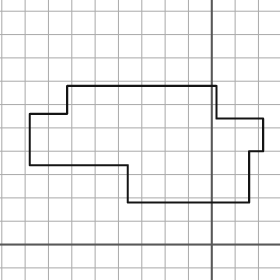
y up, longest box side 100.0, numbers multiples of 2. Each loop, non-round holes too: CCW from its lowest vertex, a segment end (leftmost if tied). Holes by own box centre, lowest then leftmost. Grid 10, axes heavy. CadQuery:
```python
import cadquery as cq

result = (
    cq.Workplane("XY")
    .moveTo(-36.0, 18.0)
    .lineTo(16.0, 18.0)
    .lineTo(16.0, 40.0)
    .lineTo(22.0, 40.0)
    .lineTo(22.0, 54.0)
    .lineTo(2.0, 54.0)
    .lineTo(2.0, 68.0)
    .lineTo(-62.0, 68.0)
    .lineTo(-62.0, 56.0)
    .lineTo(-78.0, 56.0)
    .lineTo(-78.0, 34.0)
    .lineTo(-36.0, 34.0)
    .close()
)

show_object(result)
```